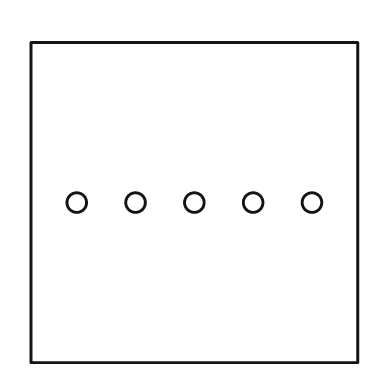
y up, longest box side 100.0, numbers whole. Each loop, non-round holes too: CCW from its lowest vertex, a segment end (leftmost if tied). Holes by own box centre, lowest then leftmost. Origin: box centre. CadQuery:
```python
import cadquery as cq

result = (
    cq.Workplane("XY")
    .moveTo(-50.0, -49.0)
    .lineTo(50.0, -49.0)
    .lineTo(50.0, 49.0)
    .lineTo(-50.0, 49.0)
    .close()
    .moveTo(-36.0, 0.0)
    .circle(3.0)
    .moveTo(-18.0, 0.0)
    .circle(3.0)
    .moveTo(0.0, 0.0)
    .circle(3.0)
    .moveTo(18.0, 0.0)
    .circle(3.0)
    .moveTo(36.0, 0.0)
    .circle(3.0)
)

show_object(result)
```